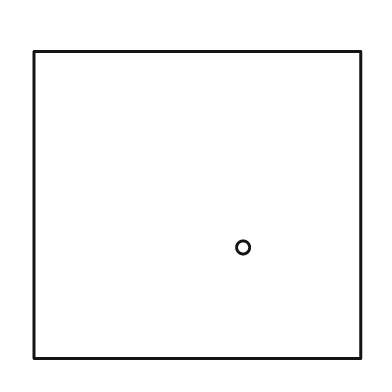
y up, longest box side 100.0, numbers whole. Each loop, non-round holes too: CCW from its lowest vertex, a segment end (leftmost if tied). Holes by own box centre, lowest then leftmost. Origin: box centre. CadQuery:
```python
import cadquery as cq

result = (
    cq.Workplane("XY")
    .moveTo(-50.0, -47.0)
    .lineTo(50.0, -47.0)
    .lineTo(50.0, 47.0)
    .lineTo(-50.0, 47.0)
    .close()
    .moveTo(14.0, -13.0)
    .circle(2.0)
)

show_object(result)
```